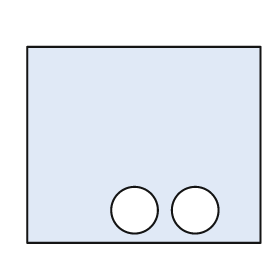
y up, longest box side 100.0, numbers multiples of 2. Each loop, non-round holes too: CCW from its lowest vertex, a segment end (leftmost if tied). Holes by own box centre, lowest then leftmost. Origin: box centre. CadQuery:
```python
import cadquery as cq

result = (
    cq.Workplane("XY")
    .moveTo(-50.0, -42.0)
    .lineTo(50.0, -42.0)
    .lineTo(50.0, 42.0)
    .lineTo(-50.0, 42.0)
    .close()
    .moveTo(-4.0, -28.0)
    .circle(10.0)
    .moveTo(22.0, -28.0)
    .circle(10.0)
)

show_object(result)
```